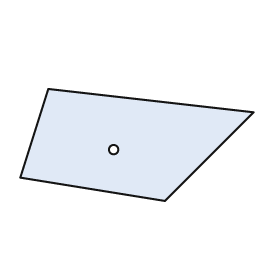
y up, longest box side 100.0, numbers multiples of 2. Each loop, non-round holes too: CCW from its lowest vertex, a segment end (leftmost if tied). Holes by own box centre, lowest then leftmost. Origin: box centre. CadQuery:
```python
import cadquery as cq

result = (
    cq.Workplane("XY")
    .moveTo(12.0, -24.0)
    .lineTo(50.0, 14.0)
    .lineTo(-38.0, 24.0)
    .lineTo(-50.0, -14.0)
    .close()
    .moveTo(-10.0, -2.0)
    .circle(2.0)
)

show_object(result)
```